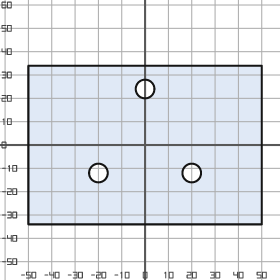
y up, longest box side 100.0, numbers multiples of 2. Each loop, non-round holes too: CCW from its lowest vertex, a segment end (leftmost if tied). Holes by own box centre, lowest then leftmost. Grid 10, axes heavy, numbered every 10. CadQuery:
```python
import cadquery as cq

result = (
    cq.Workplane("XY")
    .moveTo(-50.0, -34.0)
    .lineTo(50.0, -34.0)
    .lineTo(50.0, 34.0)
    .lineTo(-50.0, 34.0)
    .close()
    .moveTo(-20.0, -12.0)
    .circle(4.0)
    .moveTo(20.0, -12.0)
    .circle(4.0)
    .moveTo(0.0, 24.0)
    .circle(4.0)
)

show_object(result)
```